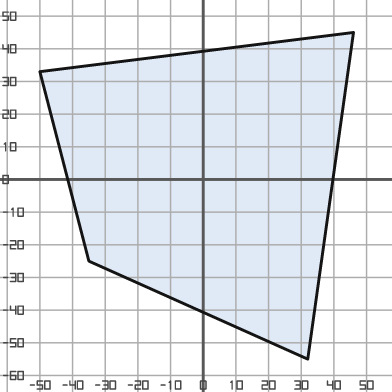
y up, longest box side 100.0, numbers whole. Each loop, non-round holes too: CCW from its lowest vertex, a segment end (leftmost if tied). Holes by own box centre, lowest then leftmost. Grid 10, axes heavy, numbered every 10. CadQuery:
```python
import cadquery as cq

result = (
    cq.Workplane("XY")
    .moveTo(32.0, -55.0)
    .lineTo(46.0, 45.0)
    .lineTo(-50.0, 33.0)
    .lineTo(-35.0, -25.0)
    .close()
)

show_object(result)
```